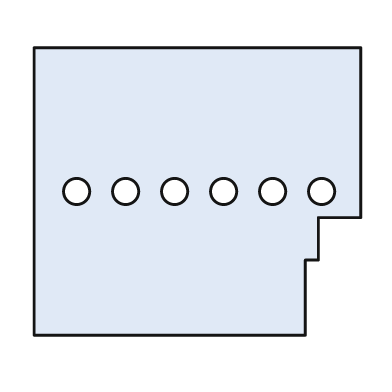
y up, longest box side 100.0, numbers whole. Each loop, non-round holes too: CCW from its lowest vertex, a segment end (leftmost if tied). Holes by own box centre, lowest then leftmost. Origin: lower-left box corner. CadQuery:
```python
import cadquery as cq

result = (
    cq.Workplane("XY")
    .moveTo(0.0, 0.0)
    .lineTo(83.0, 0.0)
    .lineTo(83.0, 23.0)
    .lineTo(87.0, 23.0)
    .lineTo(87.0, 36.0)
    .lineTo(100.0, 36.0)
    .lineTo(100.0, 88.0)
    .lineTo(0.0, 88.0)
    .close()
    .moveTo(13.0, 44.0)
    .circle(4.0)
    .moveTo(28.0, 44.0)
    .circle(4.0)
    .moveTo(43.0, 44.0)
    .circle(4.0)
    .moveTo(58.0, 44.0)
    .circle(4.0)
    .moveTo(73.0, 44.0)
    .circle(4.0)
    .moveTo(88.0, 44.0)
    .circle(4.0)
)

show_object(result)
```